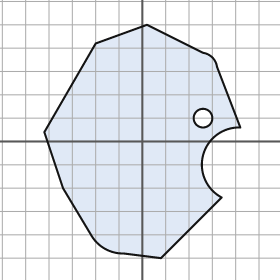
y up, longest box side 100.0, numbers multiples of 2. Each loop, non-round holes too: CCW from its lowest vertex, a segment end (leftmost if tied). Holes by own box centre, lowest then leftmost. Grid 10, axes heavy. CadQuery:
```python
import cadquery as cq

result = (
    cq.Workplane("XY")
    .moveTo(8.0, -50.0)
    .lineTo(34.0, -24.0)
    .threePointArc((26.0, -6.0), (42.0, 6.0))
    .lineTo(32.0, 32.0)
    .threePointArc((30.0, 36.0), (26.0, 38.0))
    .lineTo(2.0, 50.0)
    .lineTo(-20.0, 42.0)
    .lineTo(-42.0, 4.0)
    .lineTo(-34.0, -20.0)
    .lineTo(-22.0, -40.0)
    .threePointArc((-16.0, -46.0), (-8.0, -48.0))
    .close()
    .moveTo(26.0, 10.0)
    .circle(4.0)
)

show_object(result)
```